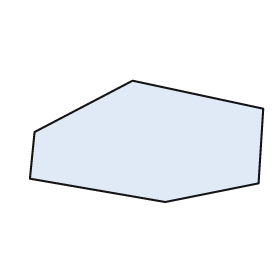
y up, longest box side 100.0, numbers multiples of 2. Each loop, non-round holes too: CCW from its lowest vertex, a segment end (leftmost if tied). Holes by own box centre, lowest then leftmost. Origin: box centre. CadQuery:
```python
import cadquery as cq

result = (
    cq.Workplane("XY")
    .moveTo(8.0, -26.0)
    .lineTo(48.0, -18.0)
    .lineTo(50.0, 14.0)
    .lineTo(-6.0, 26.0)
    .lineTo(-48.0, 4.0)
    .lineTo(-50.0, -16.0)
    .close()
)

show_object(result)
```